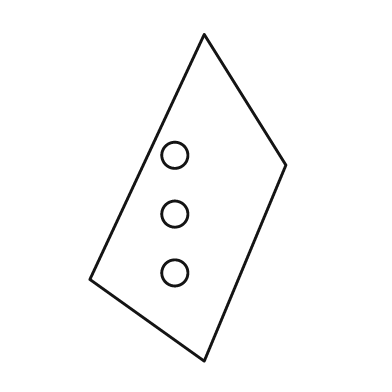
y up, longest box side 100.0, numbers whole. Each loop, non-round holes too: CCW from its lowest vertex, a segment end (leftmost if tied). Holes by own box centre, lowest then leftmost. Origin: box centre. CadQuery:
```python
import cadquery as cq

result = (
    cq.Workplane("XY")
    .moveTo(5.0, -50.0)
    .lineTo(30.0, 10.0)
    .lineTo(5.0, 50.0)
    .lineTo(-30.0, -25.0)
    .close()
    .moveTo(-4.0, -23.0)
    .circle(4.0)
    .moveTo(-4.0, -5.0)
    .circle(4.0)
    .moveTo(-4.0, 13.0)
    .circle(4.0)
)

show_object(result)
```